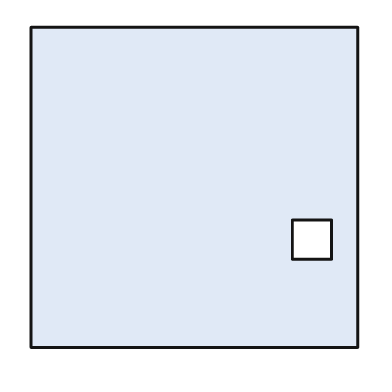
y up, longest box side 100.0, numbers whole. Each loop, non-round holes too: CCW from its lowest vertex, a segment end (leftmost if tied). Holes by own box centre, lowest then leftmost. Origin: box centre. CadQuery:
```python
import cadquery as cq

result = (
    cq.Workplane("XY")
    .moveTo(-50.0, -49.0)
    .lineTo(50.0, -49.0)
    .lineTo(50.0, 49.0)
    .lineTo(-50.0, 49.0)
    .close()
    .moveTo(30.0, -22.0)
    .lineTo(42.0, -22.0)
    .lineTo(42.0, -10.0)
    .lineTo(30.0, -10.0)
    .close()
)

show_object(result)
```